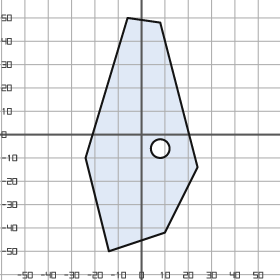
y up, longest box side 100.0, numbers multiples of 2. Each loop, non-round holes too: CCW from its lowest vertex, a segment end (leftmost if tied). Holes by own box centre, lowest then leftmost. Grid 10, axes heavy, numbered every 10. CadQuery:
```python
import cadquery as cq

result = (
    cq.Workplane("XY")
    .moveTo(-14.0, -50.0)
    .lineTo(10.0, -42.0)
    .lineTo(24.0, -14.0)
    .lineTo(8.0, 48.0)
    .lineTo(-6.0, 50.0)
    .lineTo(-24.0, -10.0)
    .close()
    .moveTo(8.0, -6.0)
    .circle(4.0)
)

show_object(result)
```